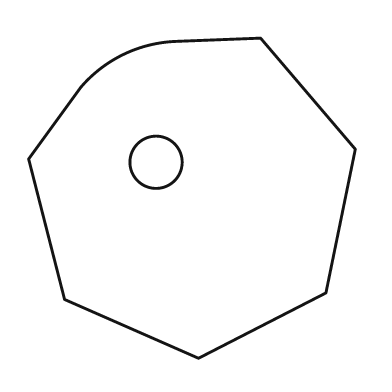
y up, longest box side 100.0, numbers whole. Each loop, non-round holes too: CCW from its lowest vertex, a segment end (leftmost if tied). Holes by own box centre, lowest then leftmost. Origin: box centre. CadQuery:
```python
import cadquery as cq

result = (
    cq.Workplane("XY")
    .moveTo(2.0, -49.0)
    .lineTo(41.0, -29.0)
    .lineTo(50.0, 15.0)
    .lineTo(21.0, 49.0)
    .lineTo(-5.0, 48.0)
    .threePointArc((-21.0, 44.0), (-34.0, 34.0))
    .lineTo(-50.0, 12.0)
    .lineTo(-39.0, -31.0)
    .close()
    .moveTo(-11.0, 11.0)
    .circle(8.0)
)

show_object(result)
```